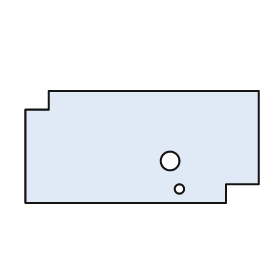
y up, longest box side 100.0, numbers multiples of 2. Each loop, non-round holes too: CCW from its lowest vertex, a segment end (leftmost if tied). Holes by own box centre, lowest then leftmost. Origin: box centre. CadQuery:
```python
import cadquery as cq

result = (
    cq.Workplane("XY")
    .moveTo(-50.0, -24.0)
    .lineTo(36.0, -24.0)
    .lineTo(36.0, -16.0)
    .lineTo(50.0, -16.0)
    .lineTo(50.0, 24.0)
    .lineTo(-40.0, 24.0)
    .lineTo(-40.0, 16.0)
    .lineTo(-50.0, 16.0)
    .close()
    .moveTo(16.0, -18.0)
    .circle(2.0)
    .moveTo(12.0, -6.0)
    .circle(4.0)
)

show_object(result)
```